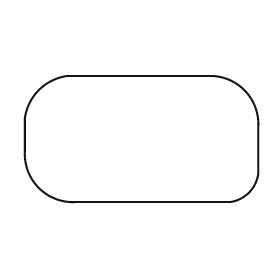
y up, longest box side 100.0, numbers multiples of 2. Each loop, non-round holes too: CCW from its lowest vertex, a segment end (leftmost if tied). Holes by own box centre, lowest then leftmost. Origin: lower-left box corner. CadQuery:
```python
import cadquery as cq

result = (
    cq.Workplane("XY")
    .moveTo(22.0, 0.0)
    .lineTo(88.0, 0.0)
    .threePointArc((96.0, 4.0), (100.0, 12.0))
    .lineTo(100.0, 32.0)
    .threePointArc((94.0, 48.0), (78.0, 54.0))
    .lineTo(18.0, 54.0)
    .threePointArc((6.0, 48.0), (0.0, 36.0))
    .lineTo(0.0, 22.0)
    .threePointArc((6.0, 6.0), (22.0, 0.0))
    .close()
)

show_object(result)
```